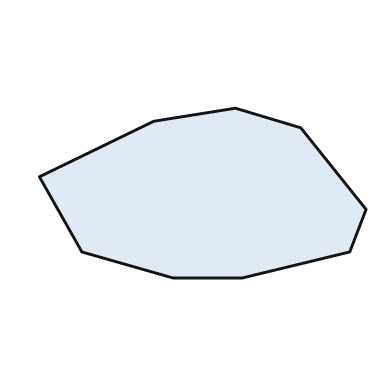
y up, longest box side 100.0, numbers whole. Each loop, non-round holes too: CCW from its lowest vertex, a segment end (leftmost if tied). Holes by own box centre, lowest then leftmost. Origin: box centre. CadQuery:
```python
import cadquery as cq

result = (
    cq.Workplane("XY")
    .moveTo(-9.0, -26.0)
    .lineTo(12.0, -26.0)
    .lineTo(45.0, -18.0)
    .lineTo(50.0, -5.0)
    .lineTo(30.0, 20.0)
    .lineTo(10.0, 26.0)
    .lineTo(-15.0, 22.0)
    .lineTo(-50.0, 5.0)
    .lineTo(-37.0, -18.0)
    .close()
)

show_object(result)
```